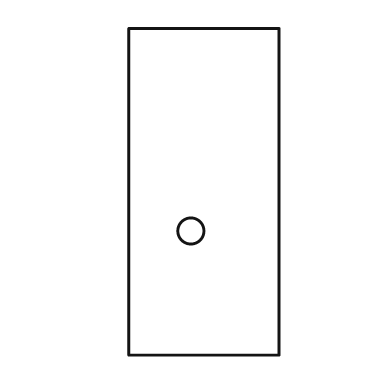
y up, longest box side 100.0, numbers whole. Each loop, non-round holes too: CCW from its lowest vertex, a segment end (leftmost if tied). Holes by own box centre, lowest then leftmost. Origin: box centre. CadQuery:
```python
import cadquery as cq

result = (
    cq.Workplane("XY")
    .moveTo(-23.0, -50.0)
    .lineTo(23.0, -50.0)
    .lineTo(23.0, 50.0)
    .lineTo(-23.0, 50.0)
    .close()
    .moveTo(-4.0, -12.0)
    .circle(4.0)
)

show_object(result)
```